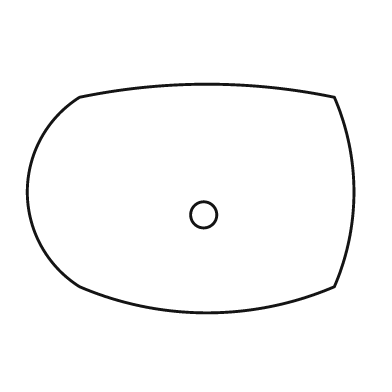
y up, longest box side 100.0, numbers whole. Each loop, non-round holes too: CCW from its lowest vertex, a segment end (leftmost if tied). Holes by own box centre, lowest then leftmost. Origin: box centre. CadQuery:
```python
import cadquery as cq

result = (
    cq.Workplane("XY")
    .moveTo(-34.0, -27.0)
    .threePointArc((5.0, -35.0), (44.0, -27.0))
    .threePointArc((50.0, 2.0), (44.0, 31.0))
    .threePointArc((5.0, 35.0), (-34.0, 31.0))
    .threePointArc((-50.0, 2.0), (-34.0, -27.0))
    .close()
    .moveTo(4.0, -5.0)
    .circle(4.0)
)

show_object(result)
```